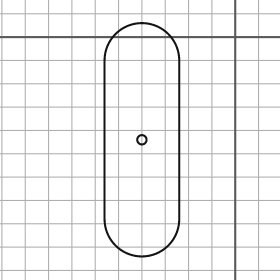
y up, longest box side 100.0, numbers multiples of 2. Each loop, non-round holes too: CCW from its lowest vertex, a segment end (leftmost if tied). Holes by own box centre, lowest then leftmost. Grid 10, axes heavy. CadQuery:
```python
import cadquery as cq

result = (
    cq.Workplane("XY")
    .moveTo(-56.0, -78.0)
    .threePointArc((-40.0, -94.0), (-24.0, -78.0))
    .lineTo(-24.0, -10.0)
    .threePointArc((-40.0, 6.0), (-56.0, -10.0))
    .close()
    .moveTo(-40.0, -44.0)
    .circle(2.0)
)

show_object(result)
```